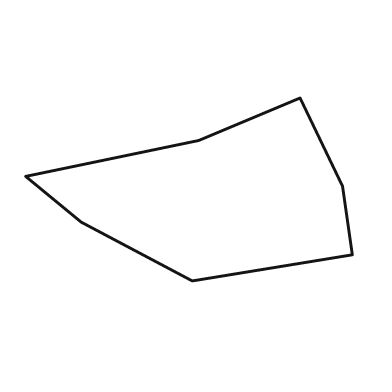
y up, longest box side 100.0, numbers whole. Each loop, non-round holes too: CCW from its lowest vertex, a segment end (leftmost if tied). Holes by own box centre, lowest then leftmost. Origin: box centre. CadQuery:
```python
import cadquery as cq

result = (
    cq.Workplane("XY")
    .moveTo(1.0, -28.0)
    .lineTo(50.0, -20.0)
    .lineTo(47.0, 1.0)
    .lineTo(34.0, 28.0)
    .lineTo(3.0, 15.0)
    .lineTo(-50.0, 4.0)
    .lineTo(-33.0, -10.0)
    .close()
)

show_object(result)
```